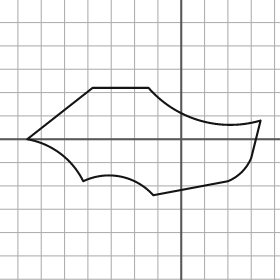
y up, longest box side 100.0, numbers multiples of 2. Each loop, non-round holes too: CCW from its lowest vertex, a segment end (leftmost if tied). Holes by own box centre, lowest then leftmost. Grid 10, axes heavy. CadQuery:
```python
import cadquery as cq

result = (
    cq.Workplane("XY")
    .moveTo(-12.0, -24.0)
    .lineTo(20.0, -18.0)
    .threePointArc((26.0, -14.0), (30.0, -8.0))
    .lineTo(34.0, 8.0)
    .threePointArc((8.0, 8.0), (-14.0, 22.0))
    .lineTo(-38.0, 22.0)
    .lineTo(-66.0, 0.0)
    .threePointArc((-52.0, -6.0), (-42.0, -18.0))
    .threePointArc((-26.0, -16.0), (-12.0, -24.0))
    .close()
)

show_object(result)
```